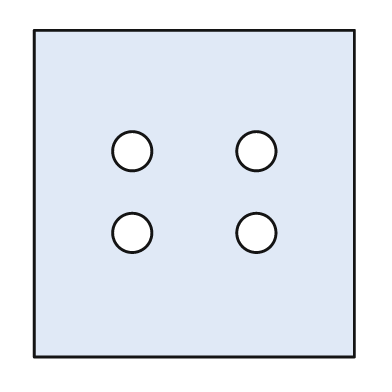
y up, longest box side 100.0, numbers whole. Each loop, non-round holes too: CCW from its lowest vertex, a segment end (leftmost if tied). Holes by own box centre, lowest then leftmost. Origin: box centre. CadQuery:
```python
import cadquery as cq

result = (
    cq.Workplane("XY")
    .moveTo(-49.0, -50.0)
    .lineTo(49.0, -50.0)
    .lineTo(49.0, 50.0)
    .lineTo(-49.0, 50.0)
    .close()
    .moveTo(-19.0, -12.0)
    .circle(6.0)
    .moveTo(19.0, -12.0)
    .circle(6.0)
    .moveTo(-19.0, 13.0)
    .circle(6.0)
    .moveTo(19.0, 13.0)
    .circle(6.0)
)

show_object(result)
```